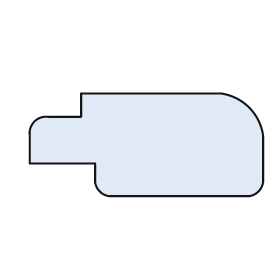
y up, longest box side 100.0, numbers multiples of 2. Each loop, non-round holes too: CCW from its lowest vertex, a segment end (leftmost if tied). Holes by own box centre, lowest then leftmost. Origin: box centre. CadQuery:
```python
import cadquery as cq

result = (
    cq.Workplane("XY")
    .moveTo(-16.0, -22.0)
    .lineTo(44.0, -22.0)
    .threePointArc((48.0, -20.0), (50.0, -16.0))
    .lineTo(50.0, 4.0)
    .threePointArc((44.0, 16.0), (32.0, 22.0))
    .lineTo(-28.0, 22.0)
    .lineTo(-28.0, 12.0)
    .lineTo(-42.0, 12.0)
    .threePointArc((-48.0, 10.0), (-50.0, 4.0))
    .lineTo(-50.0, -8.0)
    .lineTo(-22.0, -8.0)
    .lineTo(-22.0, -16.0)
    .threePointArc((-20.0, -20.0), (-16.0, -22.0))
    .close()
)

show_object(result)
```